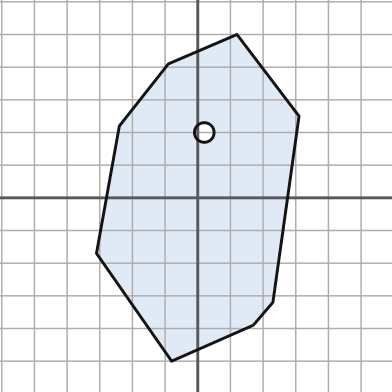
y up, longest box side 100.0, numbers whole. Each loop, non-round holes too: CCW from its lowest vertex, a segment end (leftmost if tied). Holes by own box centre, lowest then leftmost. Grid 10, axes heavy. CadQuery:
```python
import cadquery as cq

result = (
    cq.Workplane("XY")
    .moveTo(-8.0, -50.0)
    .lineTo(17.0, -39.0)
    .lineTo(23.0, -32.0)
    .lineTo(31.0, 25.0)
    .lineTo(12.0, 50.0)
    .lineTo(-9.0, 41.0)
    .lineTo(-24.0, 22.0)
    .lineTo(-31.0, -17.0)
    .close()
    .moveTo(2.0, 20.0)
    .circle(3.0)
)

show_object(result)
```